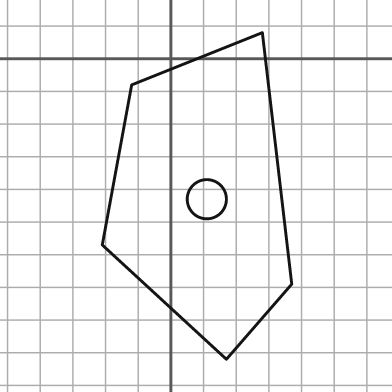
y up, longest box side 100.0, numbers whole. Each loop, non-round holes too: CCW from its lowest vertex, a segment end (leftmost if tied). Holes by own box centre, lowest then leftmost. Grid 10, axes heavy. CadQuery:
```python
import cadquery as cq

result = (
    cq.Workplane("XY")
    .moveTo(17.0, -92.0)
    .lineTo(37.0, -69.0)
    .lineTo(28.0, 8.0)
    .lineTo(-12.0, -8.0)
    .lineTo(-21.0, -57.0)
    .close()
    .moveTo(11.0, -43.0)
    .circle(6.0)
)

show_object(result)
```